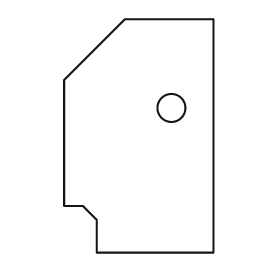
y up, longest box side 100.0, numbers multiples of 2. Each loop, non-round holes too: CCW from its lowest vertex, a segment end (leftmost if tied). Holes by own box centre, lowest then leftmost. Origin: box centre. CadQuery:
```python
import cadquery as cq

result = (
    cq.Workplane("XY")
    .moveTo(-18.0, -50.0)
    .lineTo(32.0, -50.0)
    .lineTo(32.0, 50.0)
    .lineTo(-6.0, 50.0)
    .lineTo(-32.0, 24.0)
    .lineTo(-32.0, -30.0)
    .lineTo(-24.0, -30.0)
    .lineTo(-18.0, -36.0)
    .close()
    .moveTo(14.0, 12.0)
    .circle(6.0)
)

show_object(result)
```